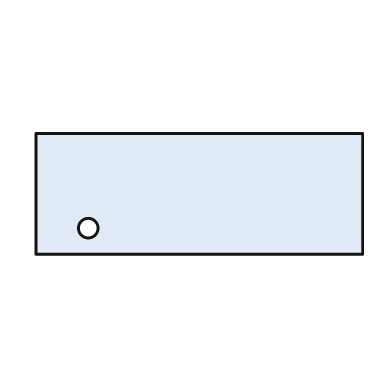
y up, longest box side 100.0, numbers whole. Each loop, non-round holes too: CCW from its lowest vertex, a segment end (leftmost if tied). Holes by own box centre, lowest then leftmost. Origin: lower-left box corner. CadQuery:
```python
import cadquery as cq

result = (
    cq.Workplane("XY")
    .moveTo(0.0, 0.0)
    .lineTo(100.0, 0.0)
    .lineTo(100.0, 37.0)
    .lineTo(0.0, 37.0)
    .close()
    .moveTo(16.0, 8.0)
    .circle(3.0)
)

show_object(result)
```